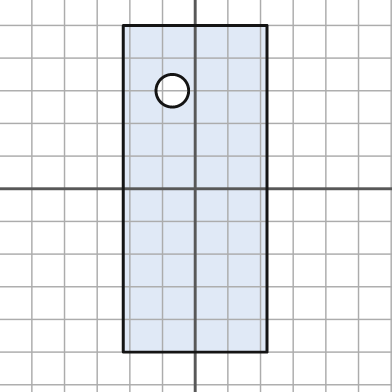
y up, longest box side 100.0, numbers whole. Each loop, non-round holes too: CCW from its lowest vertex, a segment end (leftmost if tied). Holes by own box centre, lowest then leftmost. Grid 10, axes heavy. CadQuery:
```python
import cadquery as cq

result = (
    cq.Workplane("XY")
    .moveTo(-22.0, -50.0)
    .lineTo(22.0, -50.0)
    .lineTo(22.0, 50.0)
    .lineTo(-22.0, 50.0)
    .close()
    .moveTo(-7.0, 30.0)
    .circle(5.0)
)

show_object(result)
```